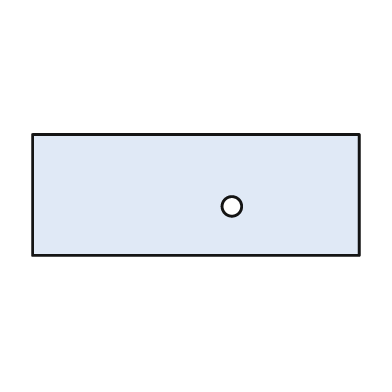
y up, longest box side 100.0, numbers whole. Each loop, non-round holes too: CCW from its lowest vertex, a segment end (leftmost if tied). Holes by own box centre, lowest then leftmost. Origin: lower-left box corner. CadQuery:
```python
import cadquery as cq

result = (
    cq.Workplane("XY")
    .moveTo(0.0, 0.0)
    .lineTo(100.0, 0.0)
    .lineTo(100.0, 37.0)
    .lineTo(0.0, 37.0)
    .close()
    .moveTo(61.0, 15.0)
    .circle(3.0)
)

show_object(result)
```